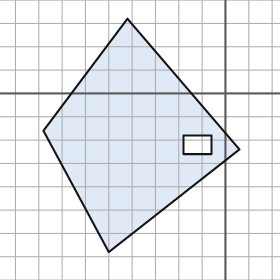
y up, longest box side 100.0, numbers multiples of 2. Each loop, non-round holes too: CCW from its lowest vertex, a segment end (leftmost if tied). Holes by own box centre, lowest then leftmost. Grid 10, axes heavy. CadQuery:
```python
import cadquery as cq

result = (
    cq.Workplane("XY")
    .moveTo(-50.0, -68.0)
    .lineTo(6.0, -24.0)
    .lineTo(-42.0, 32.0)
    .lineTo(-78.0, -16.0)
    .close()
    .moveTo(-18.0, -26.0)
    .lineTo(-6.0, -26.0)
    .lineTo(-6.0, -18.0)
    .lineTo(-18.0, -18.0)
    .close()
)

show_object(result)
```